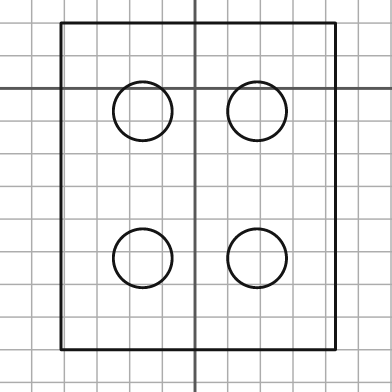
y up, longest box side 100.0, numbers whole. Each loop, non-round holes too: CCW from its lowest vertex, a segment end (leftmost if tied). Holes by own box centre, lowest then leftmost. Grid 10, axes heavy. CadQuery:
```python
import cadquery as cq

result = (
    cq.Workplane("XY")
    .moveTo(-41.0, -80.0)
    .lineTo(43.0, -80.0)
    .lineTo(43.0, 20.0)
    .lineTo(-41.0, 20.0)
    .close()
    .moveTo(-16.0, -52.0)
    .circle(9.0)
    .moveTo(19.0, -52.0)
    .circle(9.0)
    .moveTo(-16.0, -7.0)
    .circle(9.0)
    .moveTo(19.0, -7.0)
    .circle(9.0)
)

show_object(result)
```